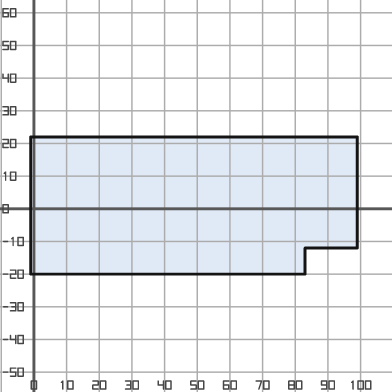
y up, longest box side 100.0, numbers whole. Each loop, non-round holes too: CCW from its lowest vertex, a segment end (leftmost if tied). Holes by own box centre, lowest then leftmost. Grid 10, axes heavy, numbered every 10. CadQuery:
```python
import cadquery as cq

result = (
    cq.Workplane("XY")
    .moveTo(-1.0, -20.0)
    .lineTo(83.0, -20.0)
    .lineTo(83.0, -12.0)
    .lineTo(99.0, -12.0)
    .lineTo(99.0, 22.0)
    .lineTo(-1.0, 22.0)
    .close()
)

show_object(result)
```